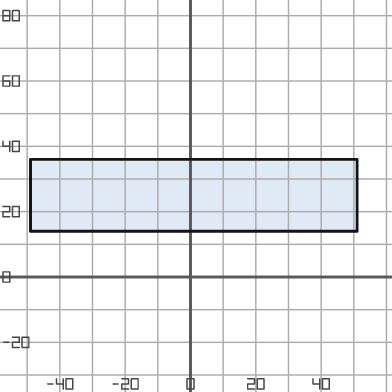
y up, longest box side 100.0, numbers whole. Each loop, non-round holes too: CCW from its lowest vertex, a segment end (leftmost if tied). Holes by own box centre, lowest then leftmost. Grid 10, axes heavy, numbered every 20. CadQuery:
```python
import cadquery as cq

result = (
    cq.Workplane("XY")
    .moveTo(-49.0, 14.0)
    .lineTo(51.0, 14.0)
    .lineTo(51.0, 36.0)
    .lineTo(-49.0, 36.0)
    .close()
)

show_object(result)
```